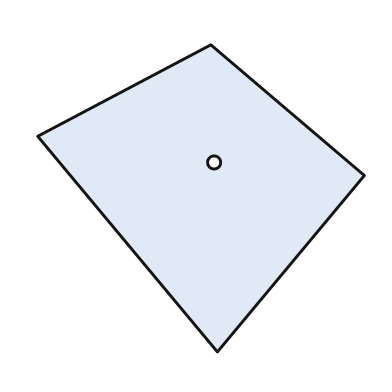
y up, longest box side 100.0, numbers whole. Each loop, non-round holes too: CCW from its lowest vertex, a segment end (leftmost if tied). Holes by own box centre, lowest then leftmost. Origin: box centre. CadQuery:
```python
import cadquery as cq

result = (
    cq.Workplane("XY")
    .moveTo(5.0, -47.0)
    .lineTo(50.0, 7.0)
    .lineTo(3.0, 47.0)
    .lineTo(-50.0, 19.0)
    .close()
    .moveTo(4.0, 11.0)
    .circle(2.0)
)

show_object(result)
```